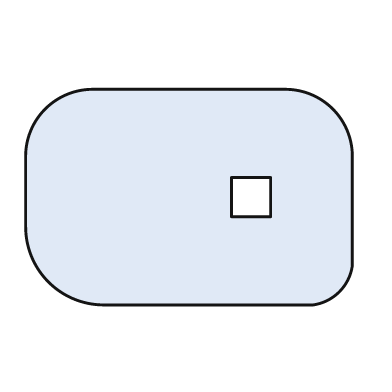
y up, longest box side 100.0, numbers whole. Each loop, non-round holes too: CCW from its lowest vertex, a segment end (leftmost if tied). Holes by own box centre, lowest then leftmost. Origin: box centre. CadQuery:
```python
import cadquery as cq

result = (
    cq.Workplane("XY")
    .moveTo(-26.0, -33.0)
    .lineTo(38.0, -33.0)
    .threePointArc((46.0, -29.0), (50.0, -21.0))
    .lineTo(50.0, 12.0)
    .threePointArc((44.0, 27.0), (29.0, 33.0))
    .lineTo(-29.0, 33.0)
    .threePointArc((-44.0, 27.0), (-50.0, 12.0))
    .lineTo(-50.0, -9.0)
    .threePointArc((-43.0, -26.0), (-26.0, -33.0))
    .close()
    .moveTo(13.0, -6.0)
    .lineTo(25.0, -6.0)
    .lineTo(25.0, 6.0)
    .lineTo(13.0, 6.0)
    .close()
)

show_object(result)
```